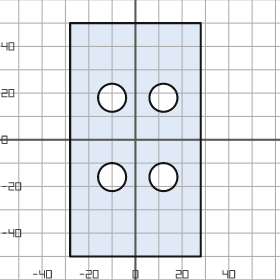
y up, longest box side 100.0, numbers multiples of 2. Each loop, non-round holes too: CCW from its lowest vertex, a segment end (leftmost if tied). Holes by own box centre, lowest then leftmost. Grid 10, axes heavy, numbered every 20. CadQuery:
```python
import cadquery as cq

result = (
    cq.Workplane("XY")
    .moveTo(-28.0, -50.0)
    .lineTo(28.0, -50.0)
    .lineTo(28.0, 50.0)
    .lineTo(-28.0, 50.0)
    .close()
    .moveTo(-10.0, -16.0)
    .circle(6.0)
    .moveTo(12.0, -16.0)
    .circle(6.0)
    .moveTo(-10.0, 18.0)
    .circle(6.0)
    .moveTo(12.0, 18.0)
    .circle(6.0)
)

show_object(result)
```